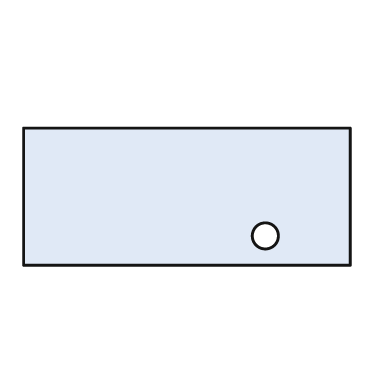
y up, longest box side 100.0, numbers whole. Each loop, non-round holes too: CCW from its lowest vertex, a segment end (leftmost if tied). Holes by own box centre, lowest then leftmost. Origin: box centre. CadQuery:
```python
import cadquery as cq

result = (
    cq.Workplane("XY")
    .moveTo(-50.0, -21.0)
    .lineTo(50.0, -21.0)
    .lineTo(50.0, 21.0)
    .lineTo(-50.0, 21.0)
    .close()
    .moveTo(24.0, -12.0)
    .circle(4.0)
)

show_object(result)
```